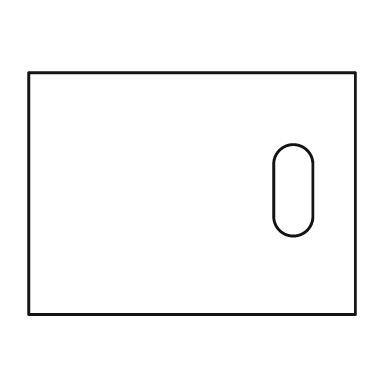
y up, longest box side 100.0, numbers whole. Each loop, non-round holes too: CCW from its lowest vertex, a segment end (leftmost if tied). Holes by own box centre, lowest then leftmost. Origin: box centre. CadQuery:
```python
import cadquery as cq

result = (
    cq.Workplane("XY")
    .moveTo(-50.0, -37.0)
    .lineTo(50.0, -37.0)
    .lineTo(50.0, 37.0)
    .lineTo(-50.0, 37.0)
    .close()
    .moveTo(25.0, -7.0)
    .threePointArc((31.0, -13.0), (37.0, -7.0))
    .lineTo(37.0, 9.0)
    .threePointArc((31.0, 15.0), (25.0, 9.0))
    .close()
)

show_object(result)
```